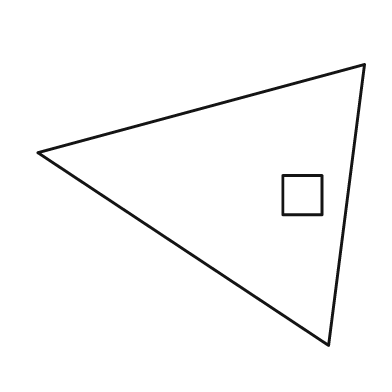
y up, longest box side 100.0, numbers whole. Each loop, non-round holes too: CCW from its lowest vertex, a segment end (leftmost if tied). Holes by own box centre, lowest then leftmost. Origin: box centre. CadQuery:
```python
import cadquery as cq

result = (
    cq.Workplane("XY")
    .moveTo(39.0, -43.0)
    .lineTo(50.0, 43.0)
    .lineTo(-50.0, 16.0)
    .close()
    .moveTo(25.0, -3.0)
    .lineTo(37.0, -3.0)
    .lineTo(37.0, 9.0)
    .lineTo(25.0, 9.0)
    .close()
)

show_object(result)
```